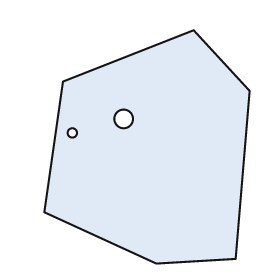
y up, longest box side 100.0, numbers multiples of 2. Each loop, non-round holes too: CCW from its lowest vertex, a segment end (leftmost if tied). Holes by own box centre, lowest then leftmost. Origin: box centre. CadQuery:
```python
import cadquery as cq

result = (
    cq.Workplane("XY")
    .moveTo(4.0, -50.0)
    .lineTo(38.0, -48.0)
    .lineTo(44.0, 24.0)
    .lineTo(20.0, 50.0)
    .lineTo(-36.0, 28.0)
    .lineTo(-44.0, -28.0)
    .close()
    .moveTo(-32.0, 6.0)
    .circle(2.0)
    .moveTo(-10.0, 12.0)
    .circle(4.0)
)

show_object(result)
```